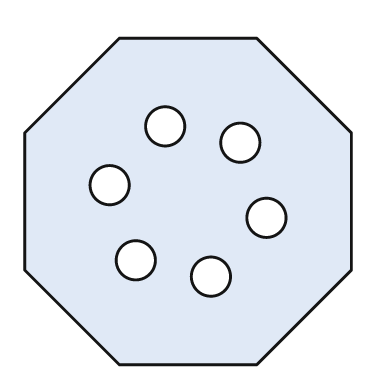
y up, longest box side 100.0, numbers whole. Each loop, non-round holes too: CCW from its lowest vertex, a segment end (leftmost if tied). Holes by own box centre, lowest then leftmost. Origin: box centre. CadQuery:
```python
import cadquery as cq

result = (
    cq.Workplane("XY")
    .moveTo(-21.0, -50.0)
    .lineTo(21.0, -50.0)
    .lineTo(50.0, -21.0)
    .lineTo(50.0, 21.0)
    .lineTo(21.0, 50.0)
    .lineTo(-21.0, 50.0)
    .lineTo(-50.0, 21.0)
    .lineTo(-50.0, -21.0)
    .close()
    .moveTo(7.0, -23.0)
    .circle(6.0)
    .moveTo(-16.0, -18.0)
    .circle(6.0)
    .moveTo(24.0, -5.0)
    .circle(6.0)
    .moveTo(-24.0, 5.0)
    .circle(6.0)
    .moveTo(16.0, 18.0)
    .circle(6.0)
    .moveTo(-7.0, 23.0)
    .circle(6.0)
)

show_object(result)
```